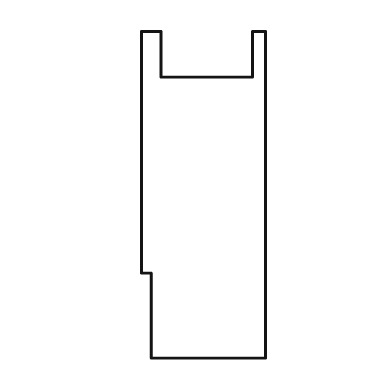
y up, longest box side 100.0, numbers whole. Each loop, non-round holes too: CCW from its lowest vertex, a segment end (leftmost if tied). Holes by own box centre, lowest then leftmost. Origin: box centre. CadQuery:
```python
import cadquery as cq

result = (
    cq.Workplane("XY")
    .moveTo(-16.0, -50.0)
    .lineTo(19.0, -50.0)
    .lineTo(19.0, 50.0)
    .lineTo(15.0, 50.0)
    .lineTo(15.0, 36.0)
    .lineTo(-13.0, 36.0)
    .lineTo(-13.0, 50.0)
    .lineTo(-19.0, 50.0)
    .lineTo(-19.0, -24.0)
    .lineTo(-16.0, -24.0)
    .close()
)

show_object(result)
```